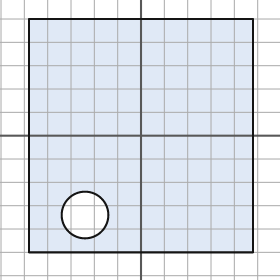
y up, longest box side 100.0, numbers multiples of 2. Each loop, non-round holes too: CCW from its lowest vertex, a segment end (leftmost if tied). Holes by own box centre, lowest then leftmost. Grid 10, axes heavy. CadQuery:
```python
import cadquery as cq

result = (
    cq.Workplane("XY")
    .moveTo(-48.0, -50.0)
    .lineTo(48.0, -50.0)
    .lineTo(48.0, 50.0)
    .lineTo(-48.0, 50.0)
    .close()
    .moveTo(-24.0, -34.0)
    .circle(10.0)
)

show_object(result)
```